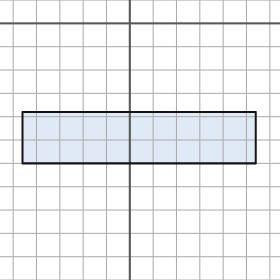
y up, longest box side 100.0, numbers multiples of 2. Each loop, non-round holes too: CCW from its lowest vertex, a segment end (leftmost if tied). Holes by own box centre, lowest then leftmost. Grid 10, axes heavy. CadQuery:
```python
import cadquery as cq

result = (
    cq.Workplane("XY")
    .moveTo(-46.0, -60.0)
    .lineTo(54.0, -60.0)
    .lineTo(54.0, -38.0)
    .lineTo(-46.0, -38.0)
    .close()
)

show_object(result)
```